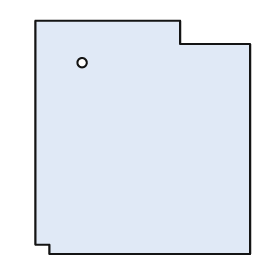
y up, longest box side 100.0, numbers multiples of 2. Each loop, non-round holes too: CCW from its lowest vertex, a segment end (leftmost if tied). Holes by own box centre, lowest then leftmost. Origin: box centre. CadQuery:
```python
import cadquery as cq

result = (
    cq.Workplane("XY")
    .moveTo(-40.0, -50.0)
    .lineTo(46.0, -50.0)
    .lineTo(46.0, 40.0)
    .lineTo(16.0, 40.0)
    .lineTo(16.0, 50.0)
    .lineTo(-46.0, 50.0)
    .lineTo(-46.0, -46.0)
    .lineTo(-40.0, -46.0)
    .close()
    .moveTo(-26.0, 32.0)
    .circle(2.0)
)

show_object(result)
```